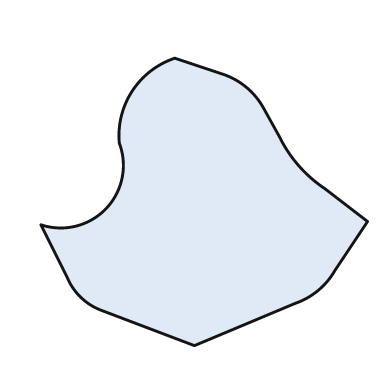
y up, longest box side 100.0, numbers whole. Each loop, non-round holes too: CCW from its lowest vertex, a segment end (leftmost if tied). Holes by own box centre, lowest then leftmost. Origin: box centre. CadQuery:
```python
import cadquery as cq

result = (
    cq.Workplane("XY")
    .moveTo(-3.0, -44.0)
    .lineTo(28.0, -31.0)
    .threePointArc((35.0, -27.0), (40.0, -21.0))
    .lineTo(50.0, -6.0)
    .lineTo(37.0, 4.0)
    .threePointArc((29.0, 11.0), (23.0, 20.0))
    .lineTo(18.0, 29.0)
    .threePointArc((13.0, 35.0), (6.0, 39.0))
    .lineTo(-9.0, 44.0)
    .threePointArc((-22.0, 34.0), (-26.0, 18.0))
    .threePointArc((-30.0, -2.0), (-50.0, -7.0))
    .lineTo(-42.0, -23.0)
    .threePointArc((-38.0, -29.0), (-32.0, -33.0))
    .close()
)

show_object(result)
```